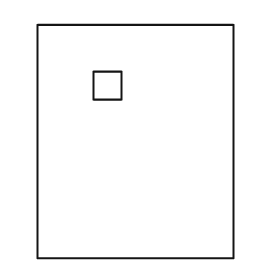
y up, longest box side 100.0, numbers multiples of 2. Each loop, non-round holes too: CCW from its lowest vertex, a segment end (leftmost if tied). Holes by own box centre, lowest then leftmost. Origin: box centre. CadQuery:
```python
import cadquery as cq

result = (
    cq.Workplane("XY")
    .moveTo(-42.0, -50.0)
    .lineTo(42.0, -50.0)
    .lineTo(42.0, 50.0)
    .lineTo(-42.0, 50.0)
    .close()
    .moveTo(-18.0, 18.0)
    .lineTo(-6.0, 18.0)
    .lineTo(-6.0, 30.0)
    .lineTo(-18.0, 30.0)
    .close()
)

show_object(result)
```